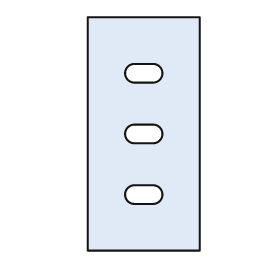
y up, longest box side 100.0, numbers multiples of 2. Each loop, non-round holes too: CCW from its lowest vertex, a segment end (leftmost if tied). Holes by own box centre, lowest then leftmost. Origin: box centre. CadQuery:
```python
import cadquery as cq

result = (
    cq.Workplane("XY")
    .moveTo(-24.0, -50.0)
    .lineTo(24.0, -50.0)
    .lineTo(24.0, 50.0)
    .lineTo(-24.0, 50.0)
    .close()
    .moveTo(-4.0, -30.0)
    .lineTo(4.0, -30.0)
    .threePointArc((8.0, -26.0), (4.0, -22.0))
    .lineTo(-4.0, -22.0)
    .threePointArc((-8.0, -26.0), (-4.0, -30.0))
    .close()
    .moveTo(-4.0, -4.0)
    .lineTo(4.0, -4.0)
    .threePointArc((8.0, 0.0), (4.0, 4.0))
    .lineTo(-4.0, 4.0)
    .threePointArc((-8.0, 0.0), (-4.0, -4.0))
    .close()
    .moveTo(-4.0, 22.0)
    .lineTo(4.0, 22.0)
    .threePointArc((8.0, 26.0), (4.0, 30.0))
    .lineTo(-4.0, 30.0)
    .threePointArc((-8.0, 26.0), (-4.0, 22.0))
    .close()
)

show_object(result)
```